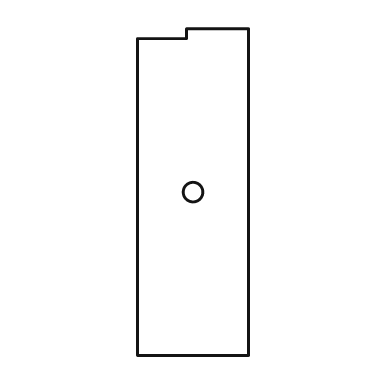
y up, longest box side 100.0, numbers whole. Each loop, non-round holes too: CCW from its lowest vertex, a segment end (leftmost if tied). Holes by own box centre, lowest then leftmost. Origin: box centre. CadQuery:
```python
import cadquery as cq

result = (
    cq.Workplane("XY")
    .moveTo(-17.0, -50.0)
    .lineTo(17.0, -50.0)
    .lineTo(17.0, 50.0)
    .lineTo(-2.0, 50.0)
    .lineTo(-2.0, 47.0)
    .lineTo(-17.0, 47.0)
    .close()
    .moveTo(0.0, 0.0)
    .circle(3.0)
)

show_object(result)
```